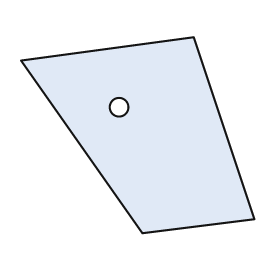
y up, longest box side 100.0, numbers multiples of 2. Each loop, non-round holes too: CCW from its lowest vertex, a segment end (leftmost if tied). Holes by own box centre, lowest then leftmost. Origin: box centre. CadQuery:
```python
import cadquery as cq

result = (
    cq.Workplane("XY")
    .moveTo(2.0, -42.0)
    .lineTo(50.0, -36.0)
    .lineTo(24.0, 42.0)
    .lineTo(-50.0, 32.0)
    .close()
    .moveTo(-8.0, 12.0)
    .circle(4.0)
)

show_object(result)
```